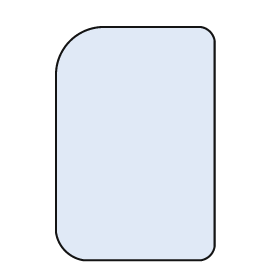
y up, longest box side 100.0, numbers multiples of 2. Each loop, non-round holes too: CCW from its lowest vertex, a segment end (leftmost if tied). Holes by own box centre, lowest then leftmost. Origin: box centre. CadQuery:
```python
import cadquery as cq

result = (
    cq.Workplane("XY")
    .moveTo(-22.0, -50.0)
    .lineTo(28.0, -50.0)
    .threePointArc((32.0, -48.0), (34.0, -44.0))
    .lineTo(34.0, 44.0)
    .threePointArc((32.0, 48.0), (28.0, 50.0))
    .lineTo(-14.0, 50.0)
    .threePointArc((-28.0, 44.0), (-34.0, 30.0))
    .lineTo(-34.0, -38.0)
    .threePointArc((-30.0, -46.0), (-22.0, -50.0))
    .close()
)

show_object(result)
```